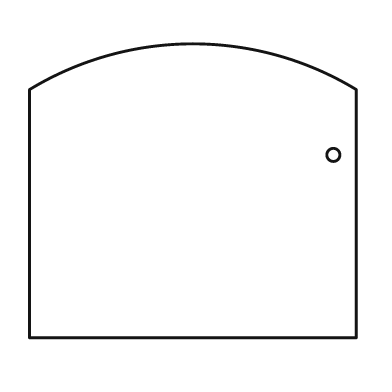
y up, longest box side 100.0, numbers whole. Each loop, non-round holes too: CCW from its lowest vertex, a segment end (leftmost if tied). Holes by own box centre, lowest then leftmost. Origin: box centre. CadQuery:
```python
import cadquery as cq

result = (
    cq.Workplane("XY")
    .moveTo(-50.0, -45.0)
    .lineTo(50.0, -45.0)
    .lineTo(50.0, 31.0)
    .threePointArc((0.0, 45.0), (-50.0, 31.0))
    .close()
    .moveTo(43.0, 11.0)
    .circle(2.0)
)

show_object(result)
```